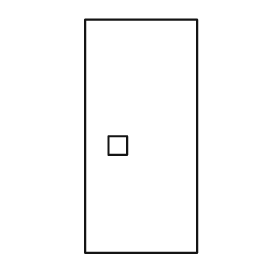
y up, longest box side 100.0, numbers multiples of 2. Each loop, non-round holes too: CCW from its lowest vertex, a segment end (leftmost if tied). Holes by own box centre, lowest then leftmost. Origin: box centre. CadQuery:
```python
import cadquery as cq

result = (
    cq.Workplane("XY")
    .moveTo(-24.0, -50.0)
    .lineTo(24.0, -50.0)
    .lineTo(24.0, 50.0)
    .lineTo(-24.0, 50.0)
    .close()
    .moveTo(-14.0, -8.0)
    .lineTo(-6.0, -8.0)
    .lineTo(-6.0, 0.0)
    .lineTo(-14.0, 0.0)
    .close()
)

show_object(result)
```